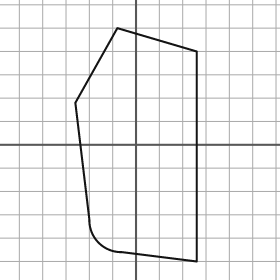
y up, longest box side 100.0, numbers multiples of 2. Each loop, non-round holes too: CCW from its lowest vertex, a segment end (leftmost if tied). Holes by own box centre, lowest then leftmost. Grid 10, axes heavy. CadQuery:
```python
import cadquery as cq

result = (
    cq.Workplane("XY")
    .moveTo(26.0, -50.0)
    .lineTo(26.0, 40.0)
    .lineTo(-8.0, 50.0)
    .lineTo(-26.0, 18.0)
    .lineTo(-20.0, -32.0)
    .threePointArc((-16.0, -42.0), (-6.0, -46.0))
    .close()
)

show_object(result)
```